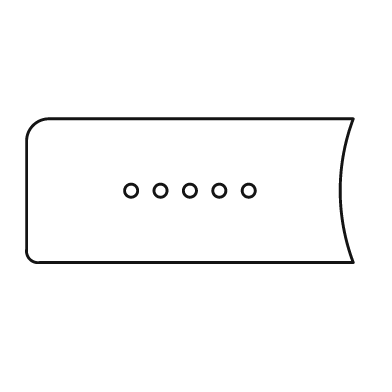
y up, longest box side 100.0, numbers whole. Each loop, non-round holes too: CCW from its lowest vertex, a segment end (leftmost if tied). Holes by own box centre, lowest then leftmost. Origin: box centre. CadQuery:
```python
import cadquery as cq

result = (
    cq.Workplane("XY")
    .moveTo(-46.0, -22.0)
    .lineTo(50.0, -22.0)
    .threePointArc((46.0, 0.0), (50.0, 22.0))
    .lineTo(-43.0, 22.0)
    .threePointArc((-48.0, 20.0), (-50.0, 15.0))
    .lineTo(-50.0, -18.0)
    .threePointArc((-49.0, -21.0), (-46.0, -22.0))
    .close()
    .moveTo(-18.0, 0.0)
    .circle(2.0)
    .moveTo(-9.0, 0.0)
    .circle(2.0)
    .moveTo(0.0, 0.0)
    .circle(2.0)
    .moveTo(9.0, 0.0)
    .circle(2.0)
    .moveTo(18.0, 0.0)
    .circle(2.0)
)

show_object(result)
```